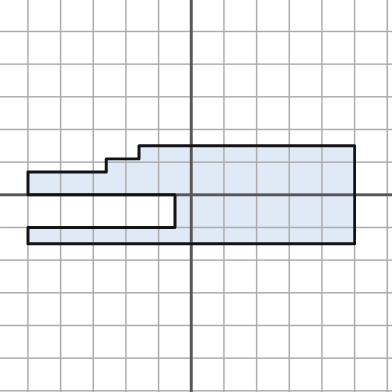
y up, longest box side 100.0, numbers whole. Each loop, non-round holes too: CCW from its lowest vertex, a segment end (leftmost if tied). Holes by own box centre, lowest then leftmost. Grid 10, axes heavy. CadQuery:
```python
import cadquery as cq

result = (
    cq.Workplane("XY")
    .moveTo(-50.0, -15.0)
    .lineTo(50.0, -15.0)
    .lineTo(50.0, 15.0)
    .lineTo(-16.0, 15.0)
    .lineTo(-16.0, 11.0)
    .lineTo(-26.0, 11.0)
    .lineTo(-26.0, 7.0)
    .lineTo(-50.0, 7.0)
    .lineTo(-50.0, 0.0)
    .lineTo(-5.0, 0.0)
    .lineTo(-5.0, -10.0)
    .lineTo(-50.0, -10.0)
    .close()
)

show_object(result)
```